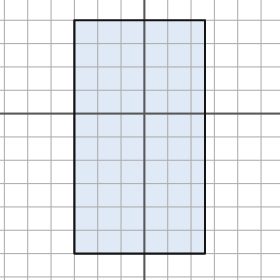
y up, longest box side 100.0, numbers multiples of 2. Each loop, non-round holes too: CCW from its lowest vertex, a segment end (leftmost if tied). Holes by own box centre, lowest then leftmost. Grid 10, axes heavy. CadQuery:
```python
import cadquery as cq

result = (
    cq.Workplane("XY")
    .moveTo(-30.0, -60.0)
    .lineTo(26.0, -60.0)
    .lineTo(26.0, 40.0)
    .lineTo(-30.0, 40.0)
    .close()
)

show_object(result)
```